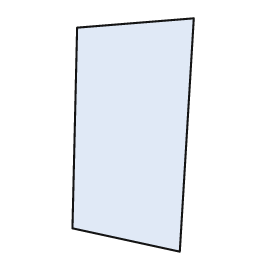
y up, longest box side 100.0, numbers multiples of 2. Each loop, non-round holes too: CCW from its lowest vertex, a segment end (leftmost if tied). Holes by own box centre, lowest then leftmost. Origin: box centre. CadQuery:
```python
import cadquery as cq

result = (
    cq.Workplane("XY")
    .moveTo(20.0, -50.0)
    .lineTo(26.0, 50.0)
    .lineTo(-24.0, 46.0)
    .lineTo(-26.0, -40.0)
    .close()
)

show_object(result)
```